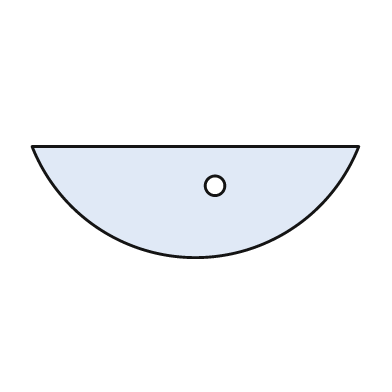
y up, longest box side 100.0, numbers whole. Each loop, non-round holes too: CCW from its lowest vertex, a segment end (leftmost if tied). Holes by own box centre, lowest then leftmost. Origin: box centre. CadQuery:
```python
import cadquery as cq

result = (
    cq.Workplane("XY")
    .moveTo(-50.0, 17.0)
    .threePointArc((0.0, -17.0), (50.0, 17.0))
    .close()
    .moveTo(6.0, 5.0)
    .circle(3.0)
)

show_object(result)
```